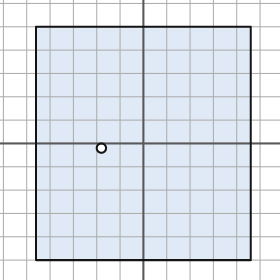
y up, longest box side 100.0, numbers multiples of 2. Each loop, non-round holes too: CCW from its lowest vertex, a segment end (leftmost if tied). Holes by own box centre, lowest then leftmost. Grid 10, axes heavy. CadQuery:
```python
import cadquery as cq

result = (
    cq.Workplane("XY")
    .moveTo(-46.0, -50.0)
    .lineTo(46.0, -50.0)
    .lineTo(46.0, 50.0)
    .lineTo(-46.0, 50.0)
    .close()
    .moveTo(-18.0, -2.0)
    .circle(2.0)
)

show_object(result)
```